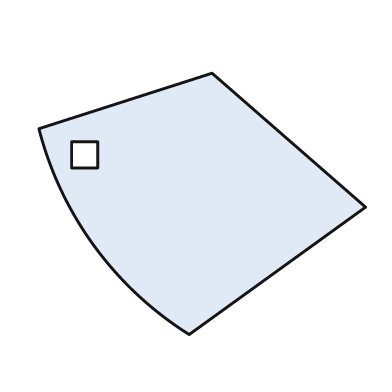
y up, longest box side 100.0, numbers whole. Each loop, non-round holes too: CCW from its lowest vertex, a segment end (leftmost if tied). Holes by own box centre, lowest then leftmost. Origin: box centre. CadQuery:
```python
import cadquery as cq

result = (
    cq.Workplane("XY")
    .moveTo(-4.0, -40.0)
    .lineTo(50.0, -1.0)
    .lineTo(3.0, 40.0)
    .lineTo(-50.0, 23.0)
    .threePointArc((-33.0, -13.0), (-4.0, -40.0))
    .close()
    .moveTo(-40.0, 11.0)
    .lineTo(-32.0, 11.0)
    .lineTo(-32.0, 19.0)
    .lineTo(-40.0, 19.0)
    .close()
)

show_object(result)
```